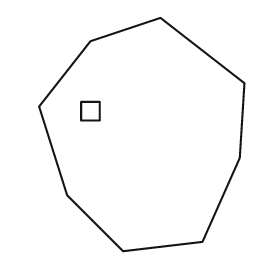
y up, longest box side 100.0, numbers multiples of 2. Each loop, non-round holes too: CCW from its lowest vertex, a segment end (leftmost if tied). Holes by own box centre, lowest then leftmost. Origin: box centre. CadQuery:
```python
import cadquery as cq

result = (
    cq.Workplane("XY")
    .moveTo(-8.0, -50.0)
    .lineTo(26.0, -46.0)
    .lineTo(42.0, -10.0)
    .lineTo(44.0, 22.0)
    .lineTo(8.0, 50.0)
    .lineTo(-22.0, 40.0)
    .lineTo(-44.0, 12.0)
    .lineTo(-32.0, -26.0)
    .close()
    .moveTo(-26.0, 6.0)
    .lineTo(-18.0, 6.0)
    .lineTo(-18.0, 14.0)
    .lineTo(-26.0, 14.0)
    .close()
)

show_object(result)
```